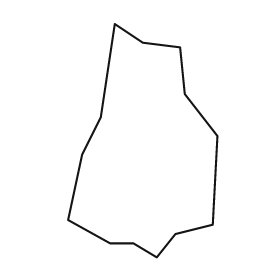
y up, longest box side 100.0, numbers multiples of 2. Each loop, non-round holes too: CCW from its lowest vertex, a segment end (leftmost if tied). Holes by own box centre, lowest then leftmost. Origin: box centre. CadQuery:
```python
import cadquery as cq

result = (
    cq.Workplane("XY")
    .moveTo(6.0, -50.0)
    .lineTo(14.0, -40.0)
    .lineTo(30.0, -36.0)
    .lineTo(32.0, 2.0)
    .lineTo(18.0, 20.0)
    .lineTo(16.0, 40.0)
    .lineTo(0.0, 42.0)
    .lineTo(-12.0, 50.0)
    .lineTo(-18.0, 10.0)
    .lineTo(-26.0, -6.0)
    .lineTo(-32.0, -34.0)
    .lineTo(-14.0, -44.0)
    .lineTo(-4.0, -44.0)
    .close()
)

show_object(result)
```